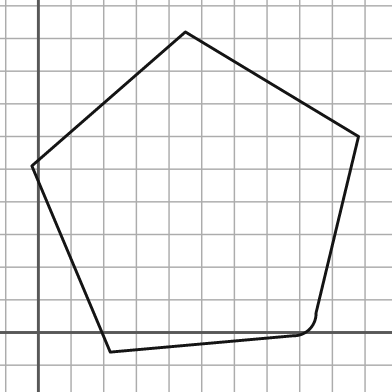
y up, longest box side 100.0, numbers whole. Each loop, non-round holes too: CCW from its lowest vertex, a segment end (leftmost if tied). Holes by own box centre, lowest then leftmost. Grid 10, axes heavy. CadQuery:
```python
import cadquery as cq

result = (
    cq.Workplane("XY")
    .moveTo(22.0, -6.0)
    .lineTo(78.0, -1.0)
    .threePointArc((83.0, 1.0), (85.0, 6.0))
    .lineTo(98.0, 60.0)
    .lineTo(45.0, 92.0)
    .lineTo(-2.0, 51.0)
    .close()
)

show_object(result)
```